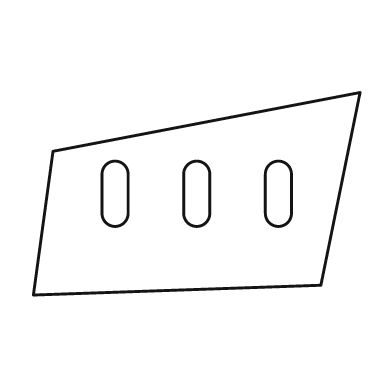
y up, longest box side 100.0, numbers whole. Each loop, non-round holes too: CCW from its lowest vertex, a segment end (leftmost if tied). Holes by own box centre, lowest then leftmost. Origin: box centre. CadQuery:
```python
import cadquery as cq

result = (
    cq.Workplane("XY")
    .moveTo(-50.0, -31.0)
    .lineTo(38.0, -28.0)
    .lineTo(50.0, 31.0)
    .lineTo(-44.0, 13.0)
    .close()
    .moveTo(-29.0, -6.0)
    .threePointArc((-25.0, -10.0), (-21.0, -6.0))
    .lineTo(-21.0, 6.0)
    .threePointArc((-25.0, 10.0), (-29.0, 6.0))
    .close()
    .moveTo(-4.0, -6.0)
    .threePointArc((0.0, -10.0), (4.0, -6.0))
    .lineTo(4.0, 6.0)
    .threePointArc((0.0, 10.0), (-4.0, 6.0))
    .close()
    .moveTo(21.0, -6.0)
    .threePointArc((25.0, -10.0), (29.0, -6.0))
    .lineTo(29.0, 6.0)
    .threePointArc((25.0, 10.0), (21.0, 6.0))
    .close()
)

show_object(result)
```